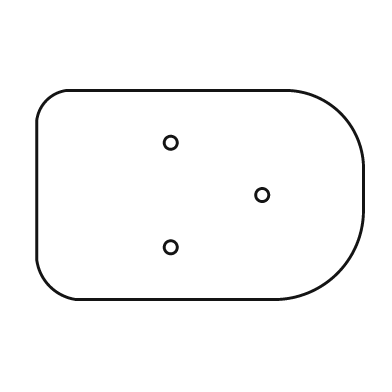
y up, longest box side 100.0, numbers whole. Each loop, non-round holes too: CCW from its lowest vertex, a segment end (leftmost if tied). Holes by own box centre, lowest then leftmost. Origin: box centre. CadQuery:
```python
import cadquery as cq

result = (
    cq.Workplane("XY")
    .moveTo(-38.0, -32.0)
    .lineTo(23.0, -32.0)
    .threePointArc((42.0, -24.0), (50.0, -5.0))
    .lineTo(50.0, 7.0)
    .threePointArc((43.0, 25.0), (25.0, 32.0))
    .lineTo(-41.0, 32.0)
    .threePointArc((-47.0, 29.0), (-50.0, 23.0))
    .lineTo(-50.0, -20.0)
    .threePointArc((-46.0, -28.0), (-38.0, -32.0))
    .close()
    .moveTo(-9.0, -16.0)
    .circle(2.0)
    .moveTo(19.0, 0.0)
    .circle(2.0)
    .moveTo(-9.0, 16.0)
    .circle(2.0)
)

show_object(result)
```